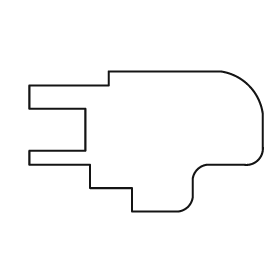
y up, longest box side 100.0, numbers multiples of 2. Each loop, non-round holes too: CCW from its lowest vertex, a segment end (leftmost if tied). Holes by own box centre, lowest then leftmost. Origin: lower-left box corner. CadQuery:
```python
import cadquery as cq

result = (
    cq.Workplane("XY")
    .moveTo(44.0, 0.0)
    .lineTo(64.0, 0.0)
    .threePointArc((68.0, 2.0), (70.0, 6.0))
    .lineTo(70.0, 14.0)
    .threePointArc((72.0, 18.0), (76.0, 20.0))
    .lineTo(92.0, 20.0)
    .threePointArc((98.0, 22.0), (100.0, 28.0))
    .lineTo(100.0, 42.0)
    .threePointArc((94.0, 54.0), (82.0, 60.0))
    .lineTo(34.0, 60.0)
    .lineTo(34.0, 54.0)
    .lineTo(0.0, 54.0)
    .lineTo(0.0, 44.0)
    .lineTo(24.0, 44.0)
    .lineTo(24.0, 26.0)
    .lineTo(0.0, 26.0)
    .lineTo(0.0, 20.0)
    .lineTo(26.0, 20.0)
    .lineTo(26.0, 10.0)
    .lineTo(44.0, 10.0)
    .close()
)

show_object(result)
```